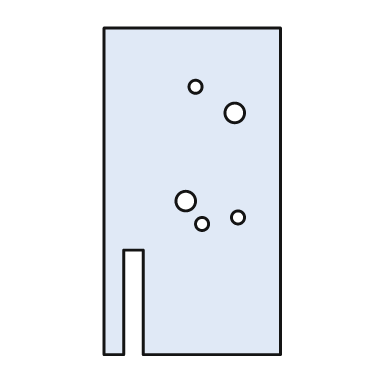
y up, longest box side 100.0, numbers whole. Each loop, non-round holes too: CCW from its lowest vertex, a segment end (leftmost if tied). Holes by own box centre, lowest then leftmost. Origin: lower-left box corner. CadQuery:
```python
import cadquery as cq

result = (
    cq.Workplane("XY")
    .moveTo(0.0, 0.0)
    .lineTo(6.0, 0.0)
    .lineTo(6.0, 32.0)
    .lineTo(12.0, 32.0)
    .lineTo(12.0, 0.0)
    .lineTo(54.0, 0.0)
    .lineTo(54.0, 100.0)
    .lineTo(0.0, 100.0)
    .close()
    .moveTo(30.0, 40.0)
    .circle(2.0)
    .moveTo(41.0, 42.0)
    .circle(2.0)
    .moveTo(25.0, 47.0)
    .circle(3.0)
    .moveTo(40.0, 74.0)
    .circle(3.0)
    .moveTo(28.0, 82.0)
    .circle(2.0)
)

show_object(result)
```